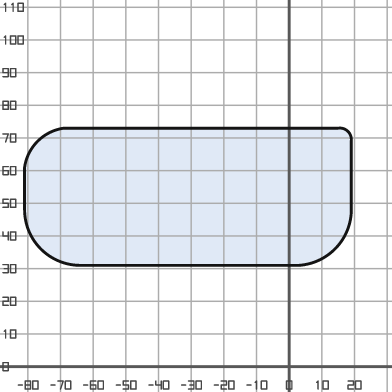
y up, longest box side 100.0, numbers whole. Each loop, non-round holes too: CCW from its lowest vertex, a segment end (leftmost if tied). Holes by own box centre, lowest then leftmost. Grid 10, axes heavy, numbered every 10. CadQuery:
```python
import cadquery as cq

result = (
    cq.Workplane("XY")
    .moveTo(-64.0, 31.0)
    .lineTo(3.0, 31.0)
    .threePointArc((14.0, 36.0), (19.0, 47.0))
    .lineTo(19.0, 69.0)
    .threePointArc((18.0, 72.0), (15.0, 73.0))
    .lineTo(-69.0, 73.0)
    .threePointArc((-77.0, 69.0), (-81.0, 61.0))
    .lineTo(-81.0, 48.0)
    .threePointArc((-76.0, 36.0), (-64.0, 31.0))
    .close()
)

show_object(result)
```